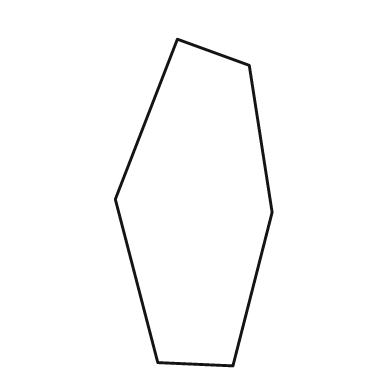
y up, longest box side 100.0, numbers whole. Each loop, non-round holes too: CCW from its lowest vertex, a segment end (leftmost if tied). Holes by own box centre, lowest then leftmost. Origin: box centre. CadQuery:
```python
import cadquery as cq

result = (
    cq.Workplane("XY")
    .moveTo(12.0, -50.0)
    .lineTo(24.0, -3.0)
    .lineTo(17.0, 42.0)
    .lineTo(-5.0, 50.0)
    .lineTo(-24.0, 1.0)
    .lineTo(-11.0, -49.0)
    .close()
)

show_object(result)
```